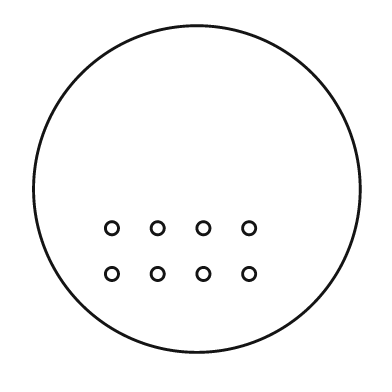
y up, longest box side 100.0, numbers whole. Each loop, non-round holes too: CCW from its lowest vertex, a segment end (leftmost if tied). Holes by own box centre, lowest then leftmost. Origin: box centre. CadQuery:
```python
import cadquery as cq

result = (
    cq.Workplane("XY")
    .moveTo(0.0, 0.0)
    .circle(50.0)
    .moveTo(-26.0, -26.0)
    .circle(2.0)
    .moveTo(-12.0, -26.0)
    .circle(2.0)
    .moveTo(2.0, -26.0)
    .circle(2.0)
    .moveTo(16.0, -26.0)
    .circle(2.0)
    .moveTo(-26.0, -12.0)
    .circle(2.0)
    .moveTo(-12.0, -12.0)
    .circle(2.0)
    .moveTo(2.0, -12.0)
    .circle(2.0)
    .moveTo(16.0, -12.0)
    .circle(2.0)
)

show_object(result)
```